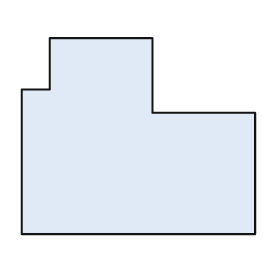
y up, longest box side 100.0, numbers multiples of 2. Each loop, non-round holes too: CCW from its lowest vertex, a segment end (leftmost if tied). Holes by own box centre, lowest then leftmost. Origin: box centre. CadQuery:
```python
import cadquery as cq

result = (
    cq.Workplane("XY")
    .moveTo(-50.0, -42.0)
    .lineTo(50.0, -42.0)
    .lineTo(50.0, 10.0)
    .lineTo(6.0, 10.0)
    .lineTo(6.0, 42.0)
    .lineTo(-38.0, 42.0)
    .lineTo(-38.0, 20.0)
    .lineTo(-50.0, 20.0)
    .close()
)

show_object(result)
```